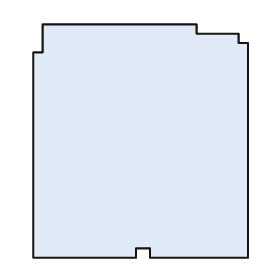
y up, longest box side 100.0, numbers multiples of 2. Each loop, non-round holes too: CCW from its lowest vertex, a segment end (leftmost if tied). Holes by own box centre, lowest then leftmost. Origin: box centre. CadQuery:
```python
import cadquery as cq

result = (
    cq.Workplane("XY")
    .moveTo(-46.0, -50.0)
    .lineTo(-2.0, -50.0)
    .lineTo(-2.0, -46.0)
    .lineTo(4.0, -46.0)
    .lineTo(4.0, -50.0)
    .lineTo(46.0, -50.0)
    .lineTo(46.0, 42.0)
    .lineTo(42.0, 42.0)
    .lineTo(42.0, 46.0)
    .lineTo(24.0, 46.0)
    .lineTo(24.0, 50.0)
    .lineTo(-42.0, 50.0)
    .lineTo(-42.0, 38.0)
    .lineTo(-46.0, 38.0)
    .close()
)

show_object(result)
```